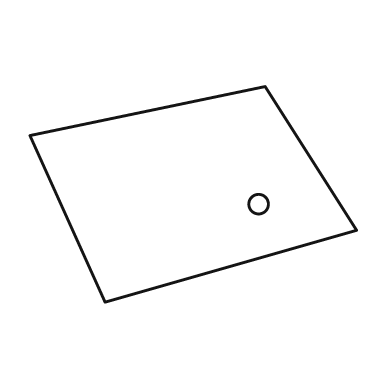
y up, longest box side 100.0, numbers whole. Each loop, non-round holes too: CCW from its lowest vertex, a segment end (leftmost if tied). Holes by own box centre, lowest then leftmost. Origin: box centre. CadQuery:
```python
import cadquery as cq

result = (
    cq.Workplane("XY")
    .moveTo(-27.0, -33.0)
    .lineTo(50.0, -11.0)
    .lineTo(22.0, 33.0)
    .lineTo(-50.0, 18.0)
    .close()
    .moveTo(20.0, -3.0)
    .circle(3.0)
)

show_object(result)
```